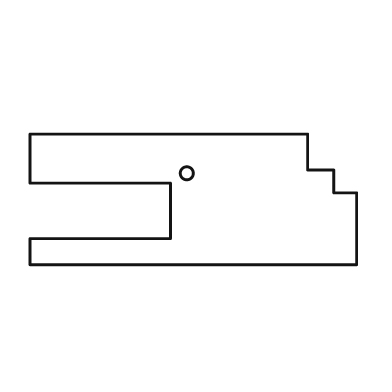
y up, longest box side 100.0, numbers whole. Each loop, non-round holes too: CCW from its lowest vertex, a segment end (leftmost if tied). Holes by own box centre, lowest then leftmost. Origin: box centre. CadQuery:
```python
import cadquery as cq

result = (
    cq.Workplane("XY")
    .moveTo(-50.0, -20.0)
    .lineTo(50.0, -20.0)
    .lineTo(50.0, 2.0)
    .lineTo(43.0, 2.0)
    .lineTo(43.0, 9.0)
    .lineTo(35.0, 9.0)
    .lineTo(35.0, 20.0)
    .lineTo(-50.0, 20.0)
    .lineTo(-50.0, 5.0)
    .lineTo(-7.0, 5.0)
    .lineTo(-7.0, -12.0)
    .lineTo(-50.0, -12.0)
    .close()
    .moveTo(-2.0, 8.0)
    .circle(2.0)
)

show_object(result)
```